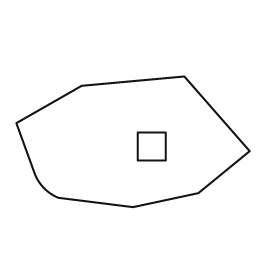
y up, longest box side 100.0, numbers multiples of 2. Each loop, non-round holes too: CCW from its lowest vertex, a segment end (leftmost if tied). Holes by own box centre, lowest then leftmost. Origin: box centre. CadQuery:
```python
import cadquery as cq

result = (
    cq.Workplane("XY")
    .moveTo(0.0, -28.0)
    .lineTo(28.0, -22.0)
    .lineTo(50.0, -4.0)
    .lineTo(22.0, 28.0)
    .lineTo(-22.0, 24.0)
    .lineTo(-50.0, 8.0)
    .lineTo(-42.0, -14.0)
    .threePointArc((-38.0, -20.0), (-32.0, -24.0))
    .close()
    .moveTo(2.0, -8.0)
    .lineTo(14.0, -8.0)
    .lineTo(14.0, 4.0)
    .lineTo(2.0, 4.0)
    .close()
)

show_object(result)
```